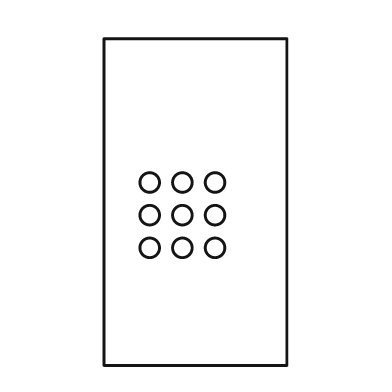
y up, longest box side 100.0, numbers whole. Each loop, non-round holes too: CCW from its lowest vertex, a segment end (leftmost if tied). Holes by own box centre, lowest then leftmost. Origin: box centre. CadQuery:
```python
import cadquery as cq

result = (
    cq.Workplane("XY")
    .moveTo(-28.0, -50.0)
    .lineTo(28.0, -50.0)
    .lineTo(28.0, 50.0)
    .lineTo(-28.0, 50.0)
    .close()
    .moveTo(-14.0, -14.0)
    .circle(3.0)
    .moveTo(-4.0, -14.0)
    .circle(3.0)
    .moveTo(6.0, -14.0)
    .circle(3.0)
    .moveTo(-14.0, -4.0)
    .circle(3.0)
    .moveTo(-4.0, -4.0)
    .circle(3.0)
    .moveTo(6.0, -4.0)
    .circle(3.0)
    .moveTo(-14.0, 6.0)
    .circle(3.0)
    .moveTo(-4.0, 6.0)
    .circle(3.0)
    .moveTo(6.0, 6.0)
    .circle(3.0)
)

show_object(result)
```